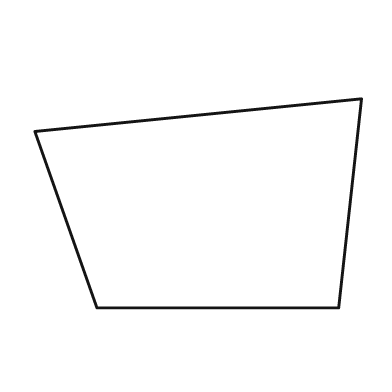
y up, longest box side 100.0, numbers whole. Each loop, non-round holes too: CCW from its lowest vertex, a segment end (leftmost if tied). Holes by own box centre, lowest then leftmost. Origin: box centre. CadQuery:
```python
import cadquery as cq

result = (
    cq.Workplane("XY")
    .moveTo(-31.0, -32.0)
    .lineTo(43.0, -32.0)
    .lineTo(50.0, 32.0)
    .lineTo(-50.0, 22.0)
    .close()
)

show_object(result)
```